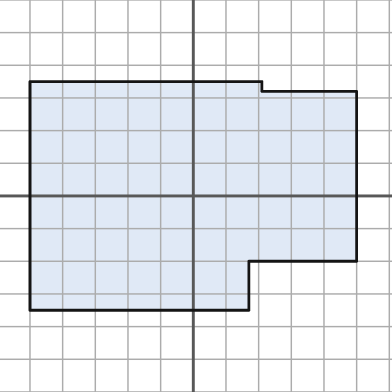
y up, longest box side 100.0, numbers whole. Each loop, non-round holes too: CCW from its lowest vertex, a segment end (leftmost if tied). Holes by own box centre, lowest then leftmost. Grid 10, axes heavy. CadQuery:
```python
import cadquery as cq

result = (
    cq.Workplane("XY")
    .moveTo(-50.0, -35.0)
    .lineTo(17.0, -35.0)
    .lineTo(17.0, -20.0)
    .lineTo(50.0, -20.0)
    .lineTo(50.0, 32.0)
    .lineTo(21.0, 32.0)
    .lineTo(21.0, 35.0)
    .lineTo(-50.0, 35.0)
    .close()
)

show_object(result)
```